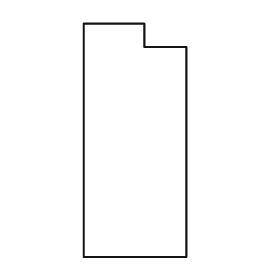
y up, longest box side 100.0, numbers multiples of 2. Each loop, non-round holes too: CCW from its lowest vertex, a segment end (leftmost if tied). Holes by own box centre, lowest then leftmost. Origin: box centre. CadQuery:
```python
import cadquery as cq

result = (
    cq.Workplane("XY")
    .moveTo(-22.0, -50.0)
    .lineTo(22.0, -50.0)
    .lineTo(22.0, 40.0)
    .lineTo(4.0, 40.0)
    .lineTo(4.0, 50.0)
    .lineTo(-22.0, 50.0)
    .close()
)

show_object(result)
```